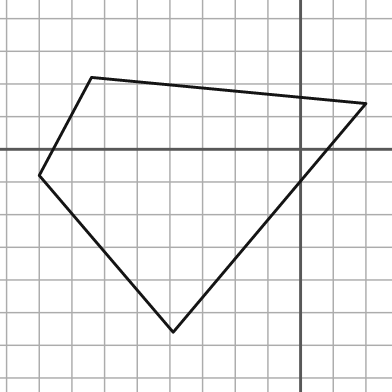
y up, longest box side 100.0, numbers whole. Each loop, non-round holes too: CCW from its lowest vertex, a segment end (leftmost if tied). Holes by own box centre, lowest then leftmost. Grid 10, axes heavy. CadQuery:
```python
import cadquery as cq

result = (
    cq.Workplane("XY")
    .moveTo(-39.0, -56.0)
    .lineTo(20.0, 14.0)
    .lineTo(-64.0, 22.0)
    .lineTo(-80.0, -8.0)
    .close()
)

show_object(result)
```